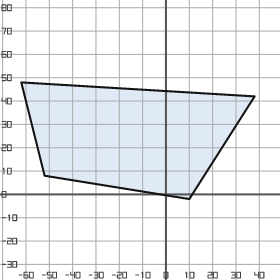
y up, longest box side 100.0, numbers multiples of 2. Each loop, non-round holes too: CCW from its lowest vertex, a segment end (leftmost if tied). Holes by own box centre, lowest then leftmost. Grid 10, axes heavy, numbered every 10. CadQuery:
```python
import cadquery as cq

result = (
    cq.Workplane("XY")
    .moveTo(10.0, -2.0)
    .lineTo(38.0, 42.0)
    .lineTo(-62.0, 48.0)
    .lineTo(-52.0, 8.0)
    .close()
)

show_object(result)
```